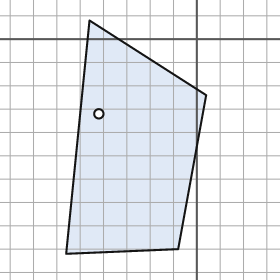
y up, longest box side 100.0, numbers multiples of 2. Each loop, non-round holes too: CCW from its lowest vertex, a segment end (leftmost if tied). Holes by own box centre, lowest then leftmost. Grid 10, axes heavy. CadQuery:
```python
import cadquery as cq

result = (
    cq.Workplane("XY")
    .moveTo(-56.0, -92.0)
    .lineTo(-8.0, -90.0)
    .lineTo(4.0, -24.0)
    .lineTo(-46.0, 8.0)
    .close()
    .moveTo(-42.0, -32.0)
    .circle(2.0)
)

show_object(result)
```